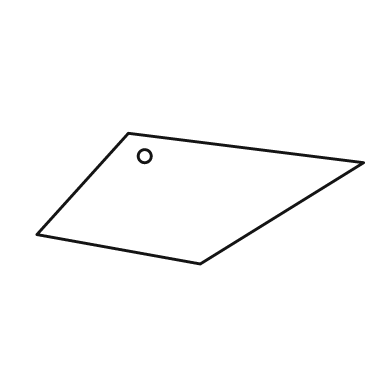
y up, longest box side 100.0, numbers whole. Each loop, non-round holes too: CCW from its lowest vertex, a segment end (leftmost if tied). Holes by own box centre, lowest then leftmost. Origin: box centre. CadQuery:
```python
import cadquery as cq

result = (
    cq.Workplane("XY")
    .moveTo(0.0, -20.0)
    .lineTo(50.0, 11.0)
    .lineTo(-22.0, 20.0)
    .lineTo(-50.0, -11.0)
    .close()
    .moveTo(-17.0, 13.0)
    .circle(2.0)
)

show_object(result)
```